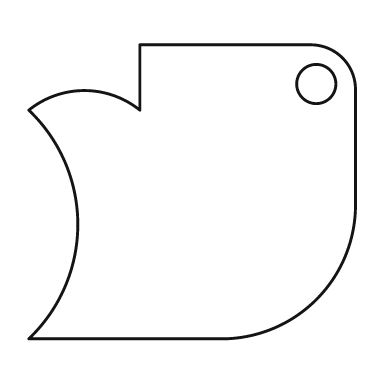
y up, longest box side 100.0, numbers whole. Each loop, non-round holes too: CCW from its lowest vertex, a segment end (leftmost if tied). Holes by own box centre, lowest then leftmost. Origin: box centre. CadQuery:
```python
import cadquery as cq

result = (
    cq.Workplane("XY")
    .moveTo(-50.0, -45.0)
    .lineTo(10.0, -45.0)
    .threePointArc((38.0, -33.0), (50.0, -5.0))
    .lineTo(50.0, 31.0)
    .threePointArc((46.0, 41.0), (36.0, 45.0))
    .lineTo(-16.0, 45.0)
    .lineTo(-16.0, 25.0)
    .threePointArc((-33.0, 31.0), (-50.0, 25.0))
    .threePointArc((-35.0, -10.0), (-50.0, -45.0))
    .close()
    .moveTo(38.0, 33.0)
    .circle(6.0)
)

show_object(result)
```